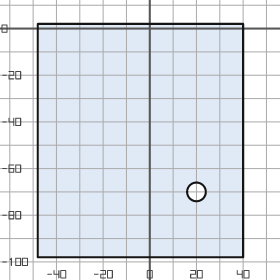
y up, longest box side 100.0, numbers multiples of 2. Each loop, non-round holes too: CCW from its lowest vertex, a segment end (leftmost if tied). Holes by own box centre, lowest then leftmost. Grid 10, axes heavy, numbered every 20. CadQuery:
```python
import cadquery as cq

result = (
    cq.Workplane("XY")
    .moveTo(-48.0, -98.0)
    .lineTo(40.0, -98.0)
    .lineTo(40.0, 2.0)
    .lineTo(-48.0, 2.0)
    .close()
    .moveTo(20.0, -70.0)
    .circle(4.0)
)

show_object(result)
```